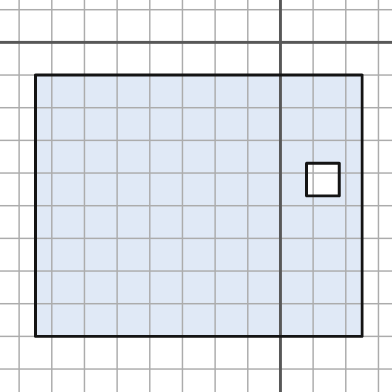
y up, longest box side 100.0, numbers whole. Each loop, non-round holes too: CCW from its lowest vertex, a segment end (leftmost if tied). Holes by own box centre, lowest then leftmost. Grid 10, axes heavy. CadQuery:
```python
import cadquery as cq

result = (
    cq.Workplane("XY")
    .moveTo(-75.0, -90.0)
    .lineTo(25.0, -90.0)
    .lineTo(25.0, -10.0)
    .lineTo(-75.0, -10.0)
    .close()
    .moveTo(8.0, -47.0)
    .lineTo(18.0, -47.0)
    .lineTo(18.0, -37.0)
    .lineTo(8.0, -37.0)
    .close()
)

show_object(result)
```